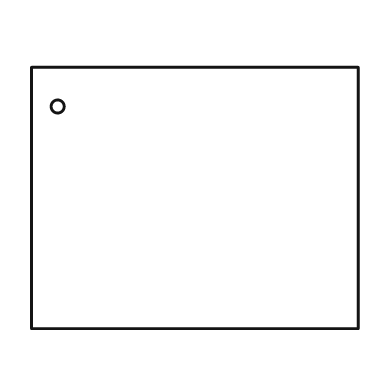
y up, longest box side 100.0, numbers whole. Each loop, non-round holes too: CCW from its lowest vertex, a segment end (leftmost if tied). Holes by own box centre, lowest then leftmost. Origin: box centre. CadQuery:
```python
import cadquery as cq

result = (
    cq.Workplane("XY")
    .moveTo(-50.0, -40.0)
    .lineTo(50.0, -40.0)
    .lineTo(50.0, 40.0)
    .lineTo(-50.0, 40.0)
    .close()
    .moveTo(-42.0, 28.0)
    .circle(2.0)
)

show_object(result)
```